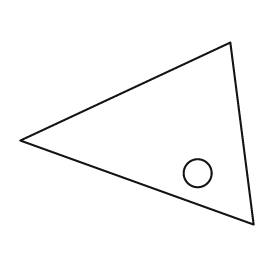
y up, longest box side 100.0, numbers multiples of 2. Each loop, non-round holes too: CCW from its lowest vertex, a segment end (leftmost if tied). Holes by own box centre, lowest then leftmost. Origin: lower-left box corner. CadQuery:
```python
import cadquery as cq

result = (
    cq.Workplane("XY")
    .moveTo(100.0, 0.0)
    .lineTo(90.0, 78.0)
    .lineTo(0.0, 36.0)
    .close()
    .moveTo(76.0, 22.0)
    .circle(6.0)
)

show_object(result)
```